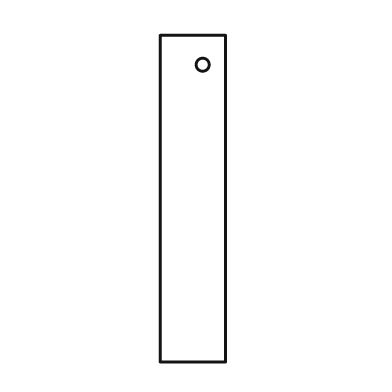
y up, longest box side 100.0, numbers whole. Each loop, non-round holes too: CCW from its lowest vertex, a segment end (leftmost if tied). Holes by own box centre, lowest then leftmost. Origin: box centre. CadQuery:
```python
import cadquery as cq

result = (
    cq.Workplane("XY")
    .moveTo(-10.0, -50.0)
    .lineTo(10.0, -50.0)
    .lineTo(10.0, 50.0)
    .lineTo(-10.0, 50.0)
    .close()
    .moveTo(3.0, 41.0)
    .circle(2.0)
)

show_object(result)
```